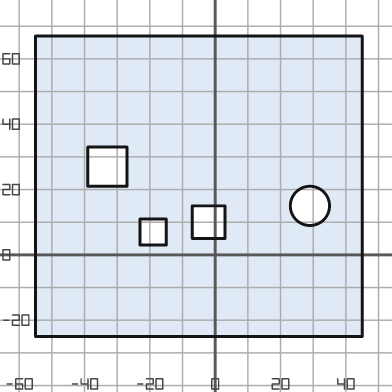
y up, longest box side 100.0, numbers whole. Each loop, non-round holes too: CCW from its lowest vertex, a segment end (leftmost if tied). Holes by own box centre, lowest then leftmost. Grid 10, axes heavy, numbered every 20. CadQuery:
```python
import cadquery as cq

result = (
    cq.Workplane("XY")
    .moveTo(-55.0, -25.0)
    .lineTo(45.0, -25.0)
    .lineTo(45.0, 67.0)
    .lineTo(-55.0, 67.0)
    .close()
    .moveTo(-23.0, 3.0)
    .lineTo(-15.0, 3.0)
    .lineTo(-15.0, 11.0)
    .lineTo(-23.0, 11.0)
    .close()
    .moveTo(-7.0, 5.0)
    .lineTo(3.0, 5.0)
    .lineTo(3.0, 15.0)
    .lineTo(-7.0, 15.0)
    .close()
    .moveTo(29.0, 15.0)
    .circle(6.0)
    .moveTo(-39.0, 21.0)
    .lineTo(-27.0, 21.0)
    .lineTo(-27.0, 33.0)
    .lineTo(-39.0, 33.0)
    .close()
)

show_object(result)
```